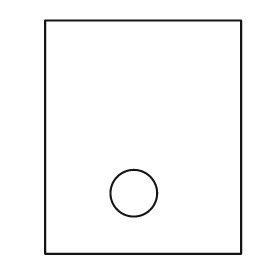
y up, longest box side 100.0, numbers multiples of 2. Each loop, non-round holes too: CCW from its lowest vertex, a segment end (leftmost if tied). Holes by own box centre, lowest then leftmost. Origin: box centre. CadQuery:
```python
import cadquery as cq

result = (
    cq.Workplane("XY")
    .moveTo(-42.0, -50.0)
    .lineTo(42.0, -50.0)
    .lineTo(42.0, 50.0)
    .lineTo(-42.0, 50.0)
    .close()
    .moveTo(-4.0, -24.0)
    .circle(10.0)
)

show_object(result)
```